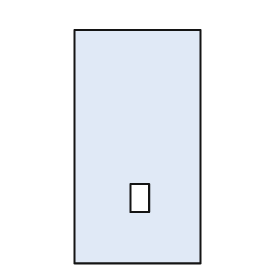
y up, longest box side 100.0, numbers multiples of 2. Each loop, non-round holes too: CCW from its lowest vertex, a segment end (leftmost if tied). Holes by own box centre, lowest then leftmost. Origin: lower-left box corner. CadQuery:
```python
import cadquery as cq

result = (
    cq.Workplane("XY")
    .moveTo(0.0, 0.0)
    .lineTo(54.0, 0.0)
    .lineTo(54.0, 100.0)
    .lineTo(0.0, 100.0)
    .close()
    .moveTo(24.0, 22.0)
    .lineTo(32.0, 22.0)
    .lineTo(32.0, 34.0)
    .lineTo(24.0, 34.0)
    .close()
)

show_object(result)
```